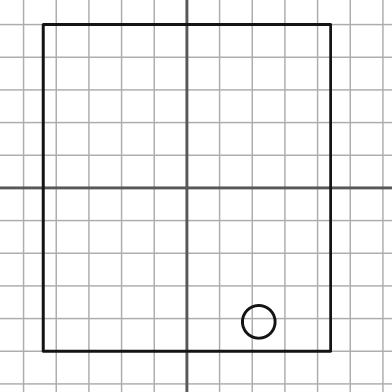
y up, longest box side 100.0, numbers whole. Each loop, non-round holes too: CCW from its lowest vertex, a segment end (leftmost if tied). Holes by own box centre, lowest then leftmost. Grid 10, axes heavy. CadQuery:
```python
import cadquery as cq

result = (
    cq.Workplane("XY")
    .moveTo(-44.0, -50.0)
    .lineTo(44.0, -50.0)
    .lineTo(44.0, 50.0)
    .lineTo(-44.0, 50.0)
    .close()
    .moveTo(22.0, -41.0)
    .circle(5.0)
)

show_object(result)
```